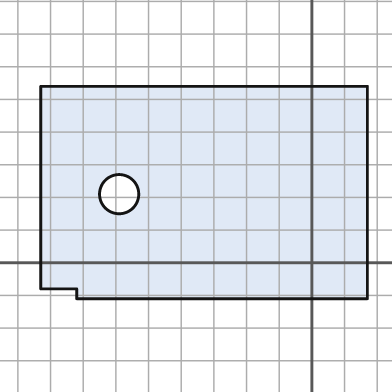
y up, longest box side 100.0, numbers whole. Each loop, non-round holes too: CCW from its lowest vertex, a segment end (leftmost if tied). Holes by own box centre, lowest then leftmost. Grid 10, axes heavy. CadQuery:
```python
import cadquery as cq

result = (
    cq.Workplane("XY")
    .moveTo(-72.0, -11.0)
    .lineTo(17.0, -11.0)
    .lineTo(17.0, 54.0)
    .lineTo(-83.0, 54.0)
    .lineTo(-83.0, -8.0)
    .lineTo(-72.0, -8.0)
    .close()
    .moveTo(-59.0, 21.0)
    .circle(6.0)
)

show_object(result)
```